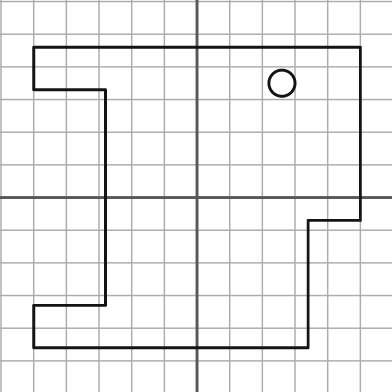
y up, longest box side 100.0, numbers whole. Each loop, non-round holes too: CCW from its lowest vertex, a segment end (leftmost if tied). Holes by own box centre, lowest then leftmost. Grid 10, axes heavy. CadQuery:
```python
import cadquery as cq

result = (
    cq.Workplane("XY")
    .moveTo(-50.0, -46.0)
    .lineTo(34.0, -46.0)
    .lineTo(34.0, -7.0)
    .lineTo(50.0, -7.0)
    .lineTo(50.0, 46.0)
    .lineTo(-50.0, 46.0)
    .lineTo(-50.0, 33.0)
    .lineTo(-28.0, 33.0)
    .lineTo(-28.0, -33.0)
    .lineTo(-50.0, -33.0)
    .close()
    .moveTo(26.0, 35.0)
    .circle(4.0)
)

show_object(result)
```